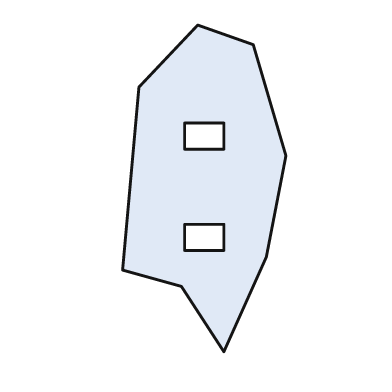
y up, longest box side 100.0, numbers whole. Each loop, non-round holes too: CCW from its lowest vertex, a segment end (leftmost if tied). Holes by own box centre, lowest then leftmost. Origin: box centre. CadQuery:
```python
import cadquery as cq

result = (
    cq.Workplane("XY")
    .moveTo(6.0, -50.0)
    .lineTo(19.0, -21.0)
    .lineTo(25.0, 10.0)
    .lineTo(15.0, 44.0)
    .lineTo(-2.0, 50.0)
    .lineTo(-20.0, 31.0)
    .lineTo(-25.0, -25.0)
    .lineTo(-7.0, -30.0)
    .close()
    .moveTo(-6.0, -19.0)
    .lineTo(6.0, -19.0)
    .lineTo(6.0, -11.0)
    .lineTo(-6.0, -11.0)
    .close()
    .moveTo(-6.0, 12.0)
    .lineTo(6.0, 12.0)
    .lineTo(6.0, 20.0)
    .lineTo(-6.0, 20.0)
    .close()
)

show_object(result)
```